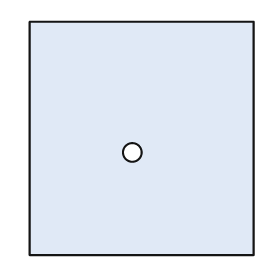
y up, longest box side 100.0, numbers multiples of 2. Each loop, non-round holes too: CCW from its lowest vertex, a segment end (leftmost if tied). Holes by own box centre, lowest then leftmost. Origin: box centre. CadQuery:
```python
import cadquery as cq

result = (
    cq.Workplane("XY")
    .moveTo(-48.0, -50.0)
    .lineTo(48.0, -50.0)
    .lineTo(48.0, 50.0)
    .lineTo(-48.0, 50.0)
    .close()
    .moveTo(-4.0, -6.0)
    .circle(4.0)
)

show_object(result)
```